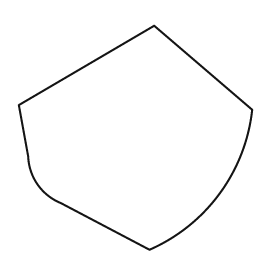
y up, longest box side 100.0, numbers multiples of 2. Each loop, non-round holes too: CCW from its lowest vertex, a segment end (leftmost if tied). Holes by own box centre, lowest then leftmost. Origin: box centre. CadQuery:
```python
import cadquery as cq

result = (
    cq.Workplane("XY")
    .moveTo(6.0, -48.0)
    .threePointArc((36.0, -24.0), (50.0, 12.0))
    .lineTo(8.0, 48.0)
    .lineTo(-50.0, 14.0)
    .lineTo(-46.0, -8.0)
    .threePointArc((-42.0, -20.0), (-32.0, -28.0))
    .close()
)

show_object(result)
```